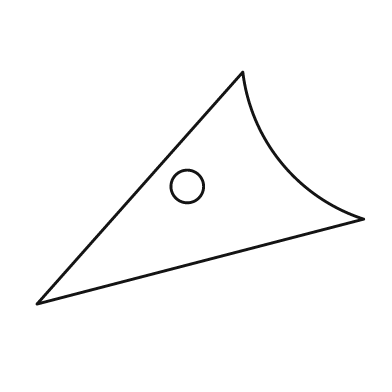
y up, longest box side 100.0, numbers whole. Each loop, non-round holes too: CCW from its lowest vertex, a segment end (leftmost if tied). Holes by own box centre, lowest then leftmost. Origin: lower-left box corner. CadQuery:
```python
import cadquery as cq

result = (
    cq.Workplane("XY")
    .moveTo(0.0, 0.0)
    .lineTo(100.0, 26.0)
    .threePointArc((75.0, 43.0), (63.0, 71.0))
    .close()
    .moveTo(46.0, 36.0)
    .circle(5.0)
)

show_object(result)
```